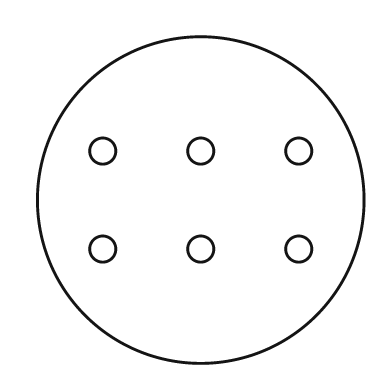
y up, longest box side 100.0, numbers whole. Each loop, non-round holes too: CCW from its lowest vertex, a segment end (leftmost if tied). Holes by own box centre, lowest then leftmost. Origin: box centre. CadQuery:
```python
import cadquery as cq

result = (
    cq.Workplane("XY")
    .moveTo(0.0, 0.0)
    .circle(50.0)
    .moveTo(-30.0, -15.0)
    .circle(4.0)
    .moveTo(0.0, -15.0)
    .circle(4.0)
    .moveTo(30.0, -15.0)
    .circle(4.0)
    .moveTo(-30.0, 15.0)
    .circle(4.0)
    .moveTo(0.0, 15.0)
    .circle(4.0)
    .moveTo(30.0, 15.0)
    .circle(4.0)
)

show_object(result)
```